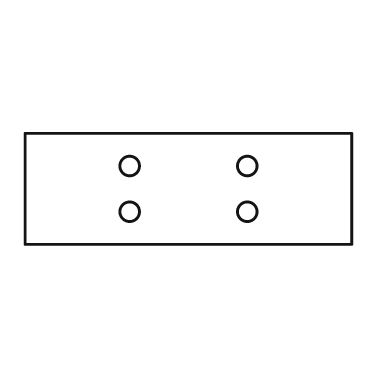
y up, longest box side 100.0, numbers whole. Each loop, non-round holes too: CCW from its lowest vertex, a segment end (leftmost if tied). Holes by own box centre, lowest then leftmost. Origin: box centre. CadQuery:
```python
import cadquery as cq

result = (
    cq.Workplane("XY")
    .moveTo(-50.0, -17.0)
    .lineTo(50.0, -17.0)
    .lineTo(50.0, 17.0)
    .lineTo(-50.0, 17.0)
    .close()
    .moveTo(-18.0, -7.0)
    .circle(3.0)
    .moveTo(18.0, -7.0)
    .circle(3.0)
    .moveTo(-18.0, 7.0)
    .circle(3.0)
    .moveTo(18.0, 7.0)
    .circle(3.0)
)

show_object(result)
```